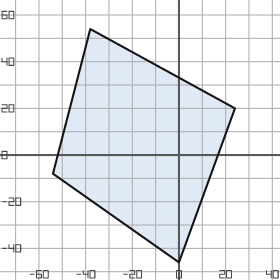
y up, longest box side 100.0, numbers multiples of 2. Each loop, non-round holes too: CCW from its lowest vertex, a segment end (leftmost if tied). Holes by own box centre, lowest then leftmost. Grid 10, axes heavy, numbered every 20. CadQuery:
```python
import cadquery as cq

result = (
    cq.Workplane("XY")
    .moveTo(0.0, -46.0)
    .lineTo(24.0, 20.0)
    .lineTo(-38.0, 54.0)
    .lineTo(-54.0, -8.0)
    .close()
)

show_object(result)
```